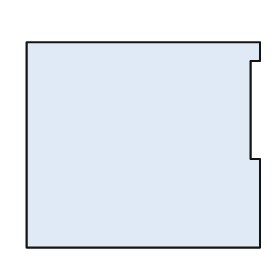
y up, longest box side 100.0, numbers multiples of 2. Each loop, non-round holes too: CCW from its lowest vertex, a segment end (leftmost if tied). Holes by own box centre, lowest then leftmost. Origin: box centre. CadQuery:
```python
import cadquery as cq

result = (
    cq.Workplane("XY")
    .moveTo(-50.0, -44.0)
    .lineTo(50.0, -44.0)
    .lineTo(50.0, -6.0)
    .lineTo(46.0, -6.0)
    .lineTo(46.0, 36.0)
    .lineTo(50.0, 36.0)
    .lineTo(50.0, 44.0)
    .lineTo(-50.0, 44.0)
    .close()
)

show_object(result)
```